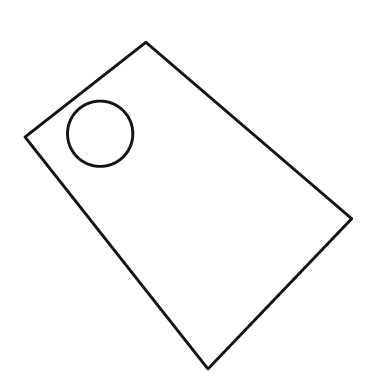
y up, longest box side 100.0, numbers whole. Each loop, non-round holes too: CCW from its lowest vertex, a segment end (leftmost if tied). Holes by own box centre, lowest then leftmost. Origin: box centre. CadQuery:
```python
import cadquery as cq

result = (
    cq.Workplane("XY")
    .moveTo(6.0, -50.0)
    .lineTo(50.0, -4.0)
    .lineTo(-13.0, 50.0)
    .lineTo(-50.0, 21.0)
    .close()
    .moveTo(-27.0, 22.0)
    .circle(10.0)
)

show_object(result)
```